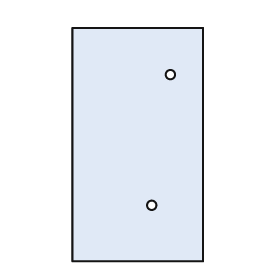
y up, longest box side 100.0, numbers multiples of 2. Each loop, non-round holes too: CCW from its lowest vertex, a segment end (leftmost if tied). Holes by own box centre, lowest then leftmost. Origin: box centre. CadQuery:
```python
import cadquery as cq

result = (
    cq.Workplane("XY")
    .moveTo(-28.0, -50.0)
    .lineTo(28.0, -50.0)
    .lineTo(28.0, 50.0)
    .lineTo(-28.0, 50.0)
    .close()
    .moveTo(6.0, -26.0)
    .circle(2.0)
    .moveTo(14.0, 30.0)
    .circle(2.0)
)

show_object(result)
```